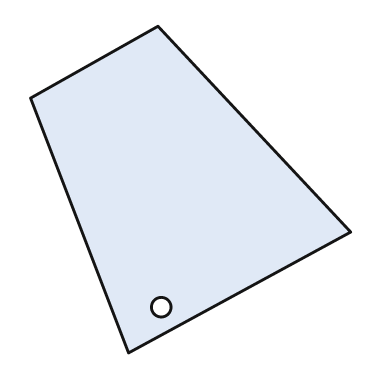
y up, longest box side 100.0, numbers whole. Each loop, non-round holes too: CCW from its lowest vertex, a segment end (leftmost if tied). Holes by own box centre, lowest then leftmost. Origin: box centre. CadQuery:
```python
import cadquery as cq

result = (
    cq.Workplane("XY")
    .moveTo(-19.0, -50.0)
    .lineTo(49.0, -13.0)
    .lineTo(-10.0, 50.0)
    .lineTo(-49.0, 28.0)
    .close()
    .moveTo(-9.0, -36.0)
    .circle(3.0)
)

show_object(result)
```